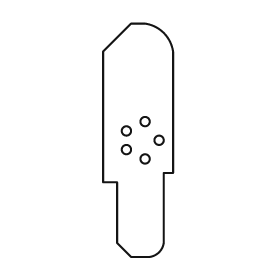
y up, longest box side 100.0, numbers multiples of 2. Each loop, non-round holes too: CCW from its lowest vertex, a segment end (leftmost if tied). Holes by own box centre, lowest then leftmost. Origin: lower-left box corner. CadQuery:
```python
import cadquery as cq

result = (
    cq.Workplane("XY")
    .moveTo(12.0, 0.0)
    .lineTo(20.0, 0.0)
    .threePointArc((24.0, 2.0), (26.0, 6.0))
    .lineTo(26.0, 36.0)
    .lineTo(30.0, 36.0)
    .lineTo(30.0, 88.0)
    .threePointArc((26.0, 96.0), (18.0, 100.0))
    .lineTo(12.0, 100.0)
    .lineTo(0.0, 88.0)
    .lineTo(0.0, 32.0)
    .lineTo(6.0, 32.0)
    .lineTo(6.0, 6.0)
    .close()
    .moveTo(18.0, 42.0)
    .circle(2.0)
    .moveTo(10.0, 46.0)
    .circle(2.0)
    .moveTo(24.0, 50.0)
    .circle(2.0)
    .moveTo(10.0, 54.0)
    .circle(2.0)
    .moveTo(18.0, 58.0)
    .circle(2.0)
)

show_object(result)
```